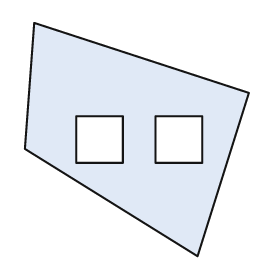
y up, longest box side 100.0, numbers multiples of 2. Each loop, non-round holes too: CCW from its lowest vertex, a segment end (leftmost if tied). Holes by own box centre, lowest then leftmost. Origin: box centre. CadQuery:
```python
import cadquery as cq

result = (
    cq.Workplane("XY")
    .moveTo(26.0, -50.0)
    .lineTo(48.0, 20.0)
    .lineTo(-44.0, 50.0)
    .lineTo(-48.0, -4.0)
    .close()
    .moveTo(-26.0, -10.0)
    .lineTo(-6.0, -10.0)
    .lineTo(-6.0, 10.0)
    .lineTo(-26.0, 10.0)
    .close()
    .moveTo(8.0, -10.0)
    .lineTo(28.0, -10.0)
    .lineTo(28.0, 10.0)
    .lineTo(8.0, 10.0)
    .close()
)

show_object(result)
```